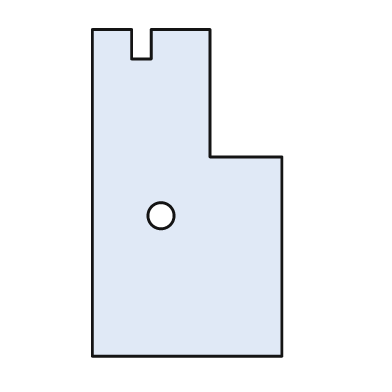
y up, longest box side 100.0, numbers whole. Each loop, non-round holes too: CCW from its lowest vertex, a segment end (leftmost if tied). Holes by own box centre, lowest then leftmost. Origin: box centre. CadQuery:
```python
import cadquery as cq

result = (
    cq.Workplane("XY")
    .moveTo(-29.0, -50.0)
    .lineTo(29.0, -50.0)
    .lineTo(29.0, 11.0)
    .lineTo(7.0, 11.0)
    .lineTo(7.0, 50.0)
    .lineTo(-11.0, 50.0)
    .lineTo(-11.0, 41.0)
    .lineTo(-17.0, 41.0)
    .lineTo(-17.0, 50.0)
    .lineTo(-29.0, 50.0)
    .close()
    .moveTo(-8.0, -7.0)
    .circle(4.0)
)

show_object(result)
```